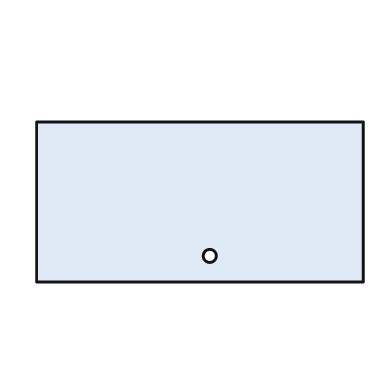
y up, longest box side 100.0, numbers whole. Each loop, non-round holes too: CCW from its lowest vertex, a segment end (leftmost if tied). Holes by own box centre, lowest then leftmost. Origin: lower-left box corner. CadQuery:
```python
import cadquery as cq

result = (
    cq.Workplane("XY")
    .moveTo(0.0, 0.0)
    .lineTo(100.0, 0.0)
    .lineTo(100.0, 49.0)
    .lineTo(0.0, 49.0)
    .close()
    .moveTo(53.0, 8.0)
    .circle(2.0)
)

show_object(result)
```